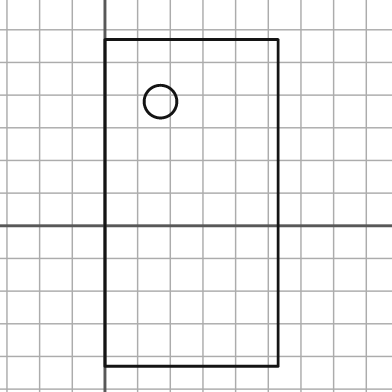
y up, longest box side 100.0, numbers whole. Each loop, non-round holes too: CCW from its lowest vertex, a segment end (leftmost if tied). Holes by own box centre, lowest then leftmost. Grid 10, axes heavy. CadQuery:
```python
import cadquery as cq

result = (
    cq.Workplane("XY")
    .moveTo(0.0, -43.0)
    .lineTo(53.0, -43.0)
    .lineTo(53.0, 57.0)
    .lineTo(0.0, 57.0)
    .close()
    .moveTo(17.0, 38.0)
    .circle(5.0)
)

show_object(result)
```